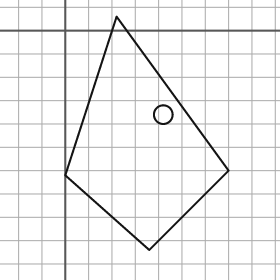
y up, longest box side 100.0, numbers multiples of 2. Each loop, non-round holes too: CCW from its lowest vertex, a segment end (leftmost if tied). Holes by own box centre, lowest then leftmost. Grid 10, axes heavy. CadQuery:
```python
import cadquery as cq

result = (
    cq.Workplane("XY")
    .moveTo(36.0, -94.0)
    .lineTo(70.0, -60.0)
    .lineTo(22.0, 6.0)
    .lineTo(0.0, -62.0)
    .close()
    .moveTo(42.0, -36.0)
    .circle(4.0)
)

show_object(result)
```